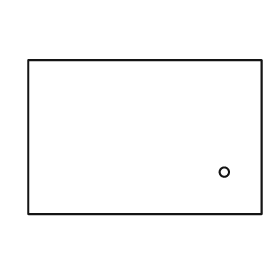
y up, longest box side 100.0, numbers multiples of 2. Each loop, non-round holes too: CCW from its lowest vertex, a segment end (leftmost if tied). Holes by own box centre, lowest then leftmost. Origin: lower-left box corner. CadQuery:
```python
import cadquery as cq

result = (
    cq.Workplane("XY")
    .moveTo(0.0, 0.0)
    .lineTo(100.0, 0.0)
    .lineTo(100.0, 66.0)
    .lineTo(0.0, 66.0)
    .close()
    .moveTo(84.0, 18.0)
    .circle(2.0)
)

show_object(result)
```